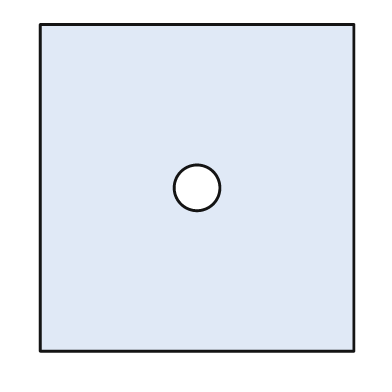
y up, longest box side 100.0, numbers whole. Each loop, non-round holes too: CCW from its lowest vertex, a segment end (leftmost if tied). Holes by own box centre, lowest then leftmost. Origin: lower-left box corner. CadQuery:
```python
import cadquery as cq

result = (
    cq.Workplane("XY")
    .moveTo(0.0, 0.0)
    .lineTo(96.0, 0.0)
    .lineTo(96.0, 100.0)
    .lineTo(0.0, 100.0)
    .close()
    .moveTo(48.0, 50.0)
    .circle(7.0)
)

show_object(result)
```